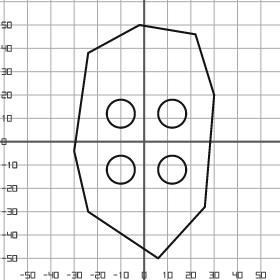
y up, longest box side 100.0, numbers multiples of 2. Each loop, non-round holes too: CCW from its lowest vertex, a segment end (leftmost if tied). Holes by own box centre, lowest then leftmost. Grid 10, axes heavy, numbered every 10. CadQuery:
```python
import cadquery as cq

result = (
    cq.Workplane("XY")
    .moveTo(6.0, -50.0)
    .lineTo(26.0, -28.0)
    .lineTo(30.0, 20.0)
    .lineTo(22.0, 46.0)
    .lineTo(-2.0, 50.0)
    .lineTo(-24.0, 38.0)
    .lineTo(-30.0, -4.0)
    .lineTo(-24.0, -30.0)
    .close()
    .moveTo(-10.0, -12.0)
    .circle(6.0)
    .moveTo(12.0, -12.0)
    .circle(6.0)
    .moveTo(-10.0, 12.0)
    .circle(6.0)
    .moveTo(12.0, 12.0)
    .circle(6.0)
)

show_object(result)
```